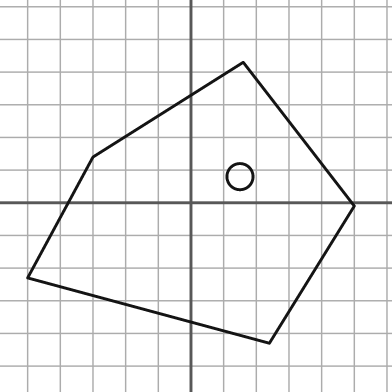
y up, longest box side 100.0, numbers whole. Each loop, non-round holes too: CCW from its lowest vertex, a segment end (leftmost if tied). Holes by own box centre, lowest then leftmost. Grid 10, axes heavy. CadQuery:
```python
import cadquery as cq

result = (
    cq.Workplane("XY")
    .moveTo(24.0, -43.0)
    .lineTo(50.0, -1.0)
    .lineTo(16.0, 43.0)
    .lineTo(-30.0, 14.0)
    .lineTo(-50.0, -23.0)
    .close()
    .moveTo(15.0, 8.0)
    .circle(4.0)
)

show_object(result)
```